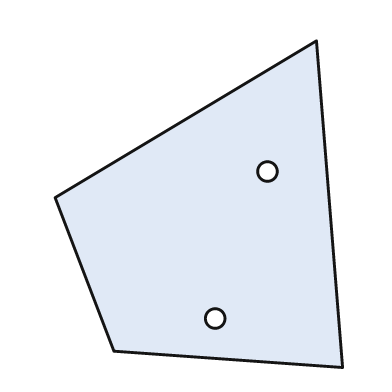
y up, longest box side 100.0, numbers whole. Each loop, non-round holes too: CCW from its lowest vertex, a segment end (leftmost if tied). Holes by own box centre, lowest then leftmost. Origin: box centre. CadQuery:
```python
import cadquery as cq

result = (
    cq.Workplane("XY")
    .moveTo(44.0, -50.0)
    .lineTo(36.0, 50.0)
    .lineTo(-44.0, 2.0)
    .lineTo(-26.0, -45.0)
    .close()
    .moveTo(5.0, -35.0)
    .circle(3.0)
    .moveTo(21.0, 10.0)
    .circle(3.0)
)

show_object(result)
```